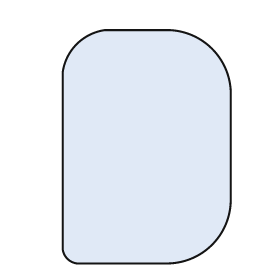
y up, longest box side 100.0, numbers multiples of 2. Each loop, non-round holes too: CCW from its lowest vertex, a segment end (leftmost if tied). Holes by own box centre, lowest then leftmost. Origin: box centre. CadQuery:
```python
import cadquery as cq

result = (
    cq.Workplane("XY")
    .moveTo(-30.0, -50.0)
    .lineTo(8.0, -50.0)
    .threePointArc((28.0, -42.0), (36.0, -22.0))
    .lineTo(36.0, 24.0)
    .threePointArc((28.0, 42.0), (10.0, 50.0))
    .lineTo(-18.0, 50.0)
    .threePointArc((-30.0, 44.0), (-36.0, 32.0))
    .lineTo(-36.0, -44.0)
    .threePointArc((-34.0, -48.0), (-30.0, -50.0))
    .close()
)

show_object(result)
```